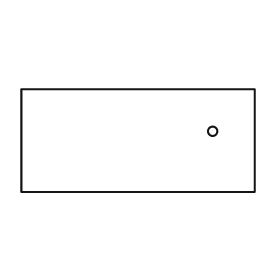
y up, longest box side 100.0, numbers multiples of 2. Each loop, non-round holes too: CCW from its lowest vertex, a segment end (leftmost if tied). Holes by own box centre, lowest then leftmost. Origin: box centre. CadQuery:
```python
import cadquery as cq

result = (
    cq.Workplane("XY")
    .moveTo(-50.0, -22.0)
    .lineTo(50.0, -22.0)
    .lineTo(50.0, 22.0)
    .lineTo(-50.0, 22.0)
    .close()
    .moveTo(32.0, 4.0)
    .circle(2.0)
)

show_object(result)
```